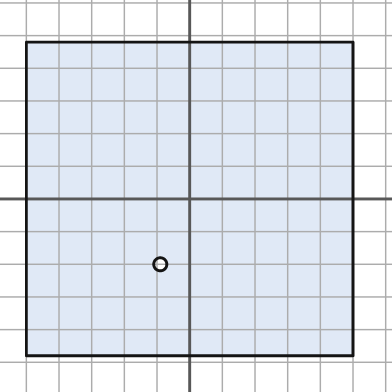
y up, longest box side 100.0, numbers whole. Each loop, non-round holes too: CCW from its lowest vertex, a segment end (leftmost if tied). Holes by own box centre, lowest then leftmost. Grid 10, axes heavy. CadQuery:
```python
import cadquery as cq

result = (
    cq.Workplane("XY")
    .moveTo(-50.0, -48.0)
    .lineTo(50.0, -48.0)
    .lineTo(50.0, 48.0)
    .lineTo(-50.0, 48.0)
    .close()
    .moveTo(-9.0, -20.0)
    .circle(2.0)
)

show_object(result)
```